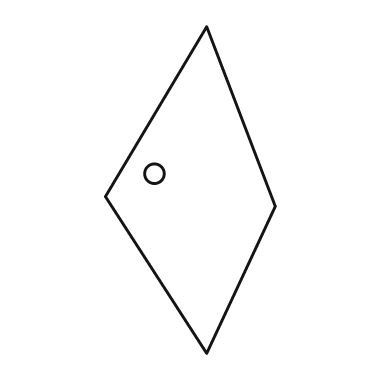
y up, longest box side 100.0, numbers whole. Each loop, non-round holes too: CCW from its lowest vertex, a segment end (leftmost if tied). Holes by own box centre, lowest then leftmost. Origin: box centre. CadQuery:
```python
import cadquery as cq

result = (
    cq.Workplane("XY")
    .moveTo(5.0, -50.0)
    .lineTo(26.0, -5.0)
    .lineTo(5.0, 50.0)
    .lineTo(-26.0, -2.0)
    .close()
    .moveTo(-11.0, 5.0)
    .circle(3.0)
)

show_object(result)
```